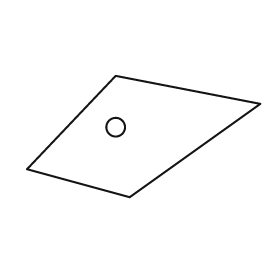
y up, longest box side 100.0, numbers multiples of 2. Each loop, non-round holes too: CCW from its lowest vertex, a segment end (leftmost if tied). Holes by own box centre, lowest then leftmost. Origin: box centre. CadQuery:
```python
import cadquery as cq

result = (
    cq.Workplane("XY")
    .moveTo(-6.0, -26.0)
    .lineTo(50.0, 14.0)
    .lineTo(-12.0, 26.0)
    .lineTo(-50.0, -14.0)
    .close()
    .moveTo(-12.0, 4.0)
    .circle(4.0)
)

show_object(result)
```